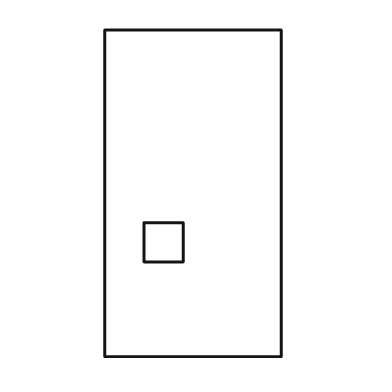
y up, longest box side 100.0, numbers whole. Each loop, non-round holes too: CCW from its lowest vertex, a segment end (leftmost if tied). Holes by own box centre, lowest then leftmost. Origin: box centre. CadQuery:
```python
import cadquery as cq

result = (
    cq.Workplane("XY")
    .moveTo(-27.0, -50.0)
    .lineTo(27.0, -50.0)
    .lineTo(27.0, 50.0)
    .lineTo(-27.0, 50.0)
    .close()
    .moveTo(-15.0, -21.0)
    .lineTo(-3.0, -21.0)
    .lineTo(-3.0, -9.0)
    .lineTo(-15.0, -9.0)
    .close()
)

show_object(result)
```